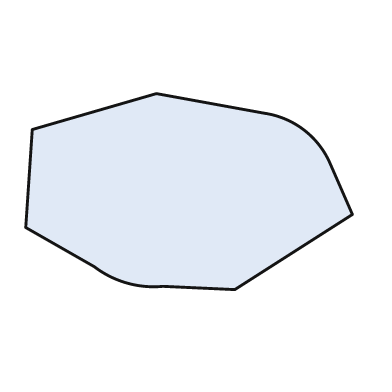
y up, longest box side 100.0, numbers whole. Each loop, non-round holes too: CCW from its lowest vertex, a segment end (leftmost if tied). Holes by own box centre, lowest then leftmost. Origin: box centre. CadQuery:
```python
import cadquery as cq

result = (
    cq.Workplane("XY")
    .moveTo(14.0, -30.0)
    .lineTo(50.0, -7.0)
    .lineTo(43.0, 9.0)
    .threePointArc((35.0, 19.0), (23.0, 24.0))
    .lineTo(-10.0, 30.0)
    .lineTo(-48.0, 19.0)
    .lineTo(-50.0, -11.0)
    .lineTo(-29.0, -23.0)
    .threePointArc((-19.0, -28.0), (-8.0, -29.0))
    .close()
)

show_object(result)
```